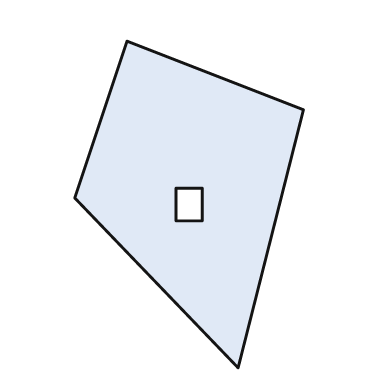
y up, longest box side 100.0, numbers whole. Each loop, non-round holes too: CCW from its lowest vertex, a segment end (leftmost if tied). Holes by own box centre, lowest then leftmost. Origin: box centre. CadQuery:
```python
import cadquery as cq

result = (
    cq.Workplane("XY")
    .moveTo(15.0, -50.0)
    .lineTo(35.0, 29.0)
    .lineTo(-19.0, 50.0)
    .lineTo(-35.0, 2.0)
    .close()
    .moveTo(-4.0, -5.0)
    .lineTo(4.0, -5.0)
    .lineTo(4.0, 5.0)
    .lineTo(-4.0, 5.0)
    .close()
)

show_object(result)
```